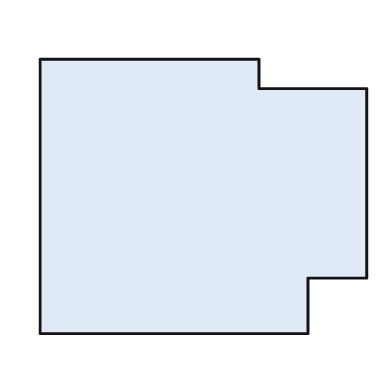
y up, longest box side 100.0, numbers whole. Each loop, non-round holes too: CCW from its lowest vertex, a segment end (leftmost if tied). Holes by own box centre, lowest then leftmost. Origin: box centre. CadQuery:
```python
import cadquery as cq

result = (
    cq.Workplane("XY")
    .moveTo(-50.0, -42.0)
    .lineTo(32.0, -42.0)
    .lineTo(32.0, -25.0)
    .lineTo(50.0, -25.0)
    .lineTo(50.0, 33.0)
    .lineTo(17.0, 33.0)
    .lineTo(17.0, 42.0)
    .lineTo(-50.0, 42.0)
    .close()
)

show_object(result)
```